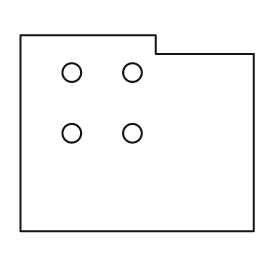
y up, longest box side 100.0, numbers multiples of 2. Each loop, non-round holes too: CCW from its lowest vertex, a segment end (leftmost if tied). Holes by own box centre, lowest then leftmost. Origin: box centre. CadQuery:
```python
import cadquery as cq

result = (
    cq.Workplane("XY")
    .moveTo(-50.0, -42.0)
    .lineTo(50.0, -42.0)
    .lineTo(50.0, 34.0)
    .lineTo(8.0, 34.0)
    .lineTo(8.0, 42.0)
    .lineTo(-50.0, 42.0)
    .close()
    .moveTo(-28.0, 0.0)
    .circle(4.0)
    .moveTo(-2.0, 0.0)
    .circle(4.0)
    .moveTo(-28.0, 26.0)
    .circle(4.0)
    .moveTo(-2.0, 26.0)
    .circle(4.0)
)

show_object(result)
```